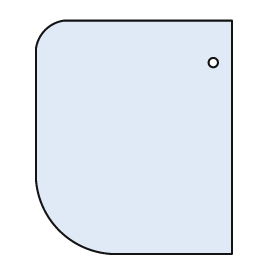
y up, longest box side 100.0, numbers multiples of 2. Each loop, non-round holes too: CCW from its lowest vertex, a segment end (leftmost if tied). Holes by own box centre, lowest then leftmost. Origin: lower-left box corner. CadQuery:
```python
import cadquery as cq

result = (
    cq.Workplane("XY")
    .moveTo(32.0, 0.0)
    .lineTo(84.0, 0.0)
    .lineTo(84.0, 100.0)
    .lineTo(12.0, 100.0)
    .threePointArc((4.0, 96.0), (0.0, 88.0))
    .lineTo(0.0, 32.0)
    .threePointArc((10.0, 10.0), (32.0, 0.0))
    .close()
    .moveTo(76.0, 82.0)
    .circle(2.0)
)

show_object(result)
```